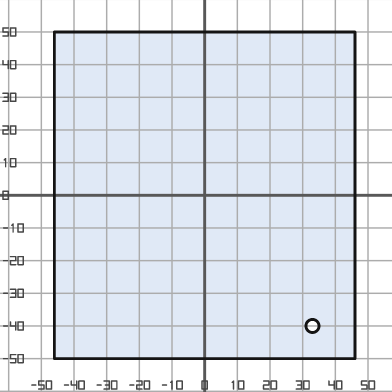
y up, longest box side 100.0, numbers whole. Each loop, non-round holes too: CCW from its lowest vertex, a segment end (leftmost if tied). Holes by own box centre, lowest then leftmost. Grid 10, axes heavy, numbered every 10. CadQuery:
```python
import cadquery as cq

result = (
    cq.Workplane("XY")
    .moveTo(-46.0, -50.0)
    .lineTo(46.0, -50.0)
    .lineTo(46.0, 50.0)
    .lineTo(-46.0, 50.0)
    .close()
    .moveTo(33.0, -40.0)
    .circle(2.0)
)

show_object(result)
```